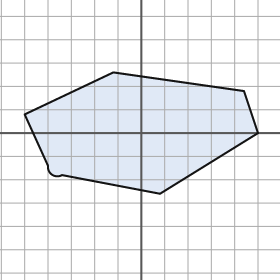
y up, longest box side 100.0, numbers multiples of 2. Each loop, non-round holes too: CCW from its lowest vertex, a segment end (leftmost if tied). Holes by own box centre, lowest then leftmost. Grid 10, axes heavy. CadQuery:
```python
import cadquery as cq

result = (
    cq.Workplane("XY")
    .moveTo(8.0, -26.0)
    .lineTo(50.0, 0.0)
    .lineTo(44.0, 18.0)
    .lineTo(-12.0, 26.0)
    .lineTo(-50.0, 8.0)
    .lineTo(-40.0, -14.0)
    .threePointArc((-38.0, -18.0), (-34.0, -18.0))
    .close()
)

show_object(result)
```